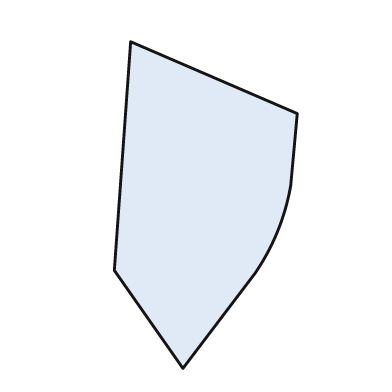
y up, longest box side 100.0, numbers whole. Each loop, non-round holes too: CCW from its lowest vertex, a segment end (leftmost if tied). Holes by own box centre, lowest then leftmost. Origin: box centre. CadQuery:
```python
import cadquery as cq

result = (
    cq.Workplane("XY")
    .moveTo(-7.0, -50.0)
    .lineTo(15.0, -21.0)
    .threePointArc((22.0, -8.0), (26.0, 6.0))
    .lineTo(28.0, 28.0)
    .lineTo(-23.0, 50.0)
    .lineTo(-28.0, -20.0)
    .close()
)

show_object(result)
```